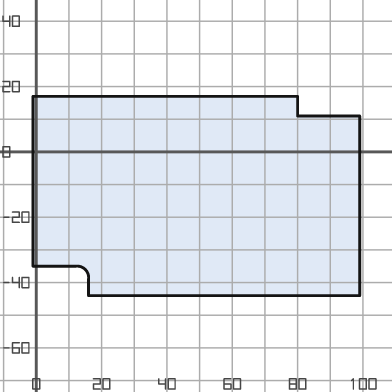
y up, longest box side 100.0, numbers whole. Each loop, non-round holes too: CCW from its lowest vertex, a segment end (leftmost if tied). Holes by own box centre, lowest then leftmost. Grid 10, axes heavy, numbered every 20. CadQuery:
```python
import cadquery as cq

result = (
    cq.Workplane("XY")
    .moveTo(16.0, -44.0)
    .lineTo(99.0, -44.0)
    .lineTo(99.0, 11.0)
    .lineTo(80.0, 11.0)
    .lineTo(80.0, 17.0)
    .lineTo(-1.0, 17.0)
    .lineTo(-1.0, -35.0)
    .lineTo(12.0, -35.0)
    .threePointArc((15.0, -36.0), (16.0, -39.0))
    .close()
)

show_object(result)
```